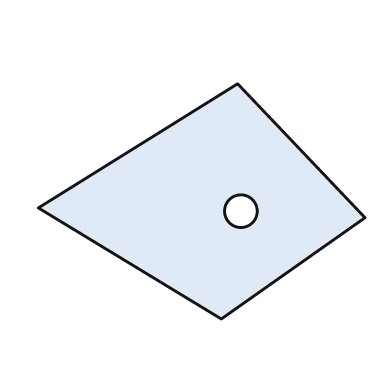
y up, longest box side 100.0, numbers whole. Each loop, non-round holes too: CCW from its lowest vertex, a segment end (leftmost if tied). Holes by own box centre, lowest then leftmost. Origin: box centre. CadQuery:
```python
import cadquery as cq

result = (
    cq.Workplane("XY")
    .moveTo(6.0, -36.0)
    .lineTo(50.0, -5.0)
    .lineTo(11.0, 36.0)
    .lineTo(-50.0, -2.0)
    .close()
    .moveTo(12.0, -3.0)
    .circle(5.0)
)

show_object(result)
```